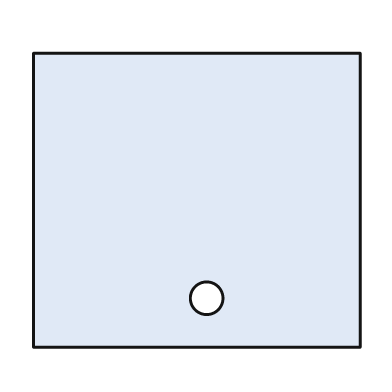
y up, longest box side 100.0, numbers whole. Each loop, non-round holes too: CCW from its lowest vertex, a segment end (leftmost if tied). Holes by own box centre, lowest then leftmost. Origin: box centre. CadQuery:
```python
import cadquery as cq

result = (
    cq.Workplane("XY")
    .moveTo(-50.0, -45.0)
    .lineTo(50.0, -45.0)
    .lineTo(50.0, 45.0)
    .lineTo(-50.0, 45.0)
    .close()
    .moveTo(3.0, -30.0)
    .circle(5.0)
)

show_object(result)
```